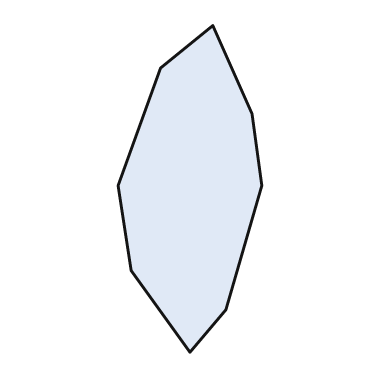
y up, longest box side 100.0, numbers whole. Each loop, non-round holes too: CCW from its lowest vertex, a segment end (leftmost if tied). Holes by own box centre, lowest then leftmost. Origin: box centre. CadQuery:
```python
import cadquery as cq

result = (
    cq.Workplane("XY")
    .moveTo(0.0, -50.0)
    .lineTo(11.0, -37.0)
    .lineTo(22.0, 1.0)
    .lineTo(19.0, 23.0)
    .lineTo(7.0, 50.0)
    .lineTo(-9.0, 37.0)
    .lineTo(-22.0, 1.0)
    .lineTo(-18.0, -25.0)
    .close()
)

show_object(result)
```